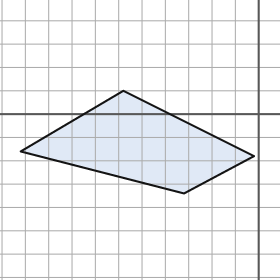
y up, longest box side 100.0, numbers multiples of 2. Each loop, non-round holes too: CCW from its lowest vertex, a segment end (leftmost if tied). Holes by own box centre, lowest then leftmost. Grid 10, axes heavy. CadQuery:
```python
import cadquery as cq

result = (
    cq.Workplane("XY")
    .moveTo(-32.0, -34.0)
    .lineTo(-2.0, -18.0)
    .lineTo(-58.0, 10.0)
    .lineTo(-102.0, -16.0)
    .close()
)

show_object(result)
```